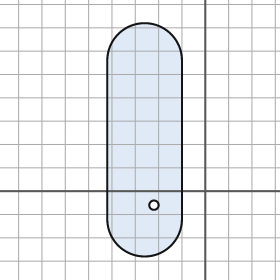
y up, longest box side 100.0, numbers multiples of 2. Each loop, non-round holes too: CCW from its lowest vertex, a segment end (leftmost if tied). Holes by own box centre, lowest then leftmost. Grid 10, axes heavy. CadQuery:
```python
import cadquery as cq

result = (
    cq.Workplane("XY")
    .moveTo(-42.0, -12.0)
    .threePointArc((-26.0, -28.0), (-10.0, -12.0))
    .lineTo(-10.0, 56.0)
    .threePointArc((-26.0, 72.0), (-42.0, 56.0))
    .close()
    .moveTo(-22.0, -6.0)
    .circle(2.0)
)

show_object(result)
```